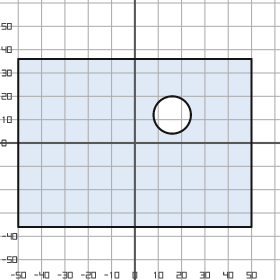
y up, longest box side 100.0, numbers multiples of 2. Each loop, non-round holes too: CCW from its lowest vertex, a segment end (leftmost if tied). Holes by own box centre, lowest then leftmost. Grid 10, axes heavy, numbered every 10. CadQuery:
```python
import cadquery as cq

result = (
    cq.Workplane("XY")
    .moveTo(-50.0, -36.0)
    .lineTo(50.0, -36.0)
    .lineTo(50.0, 36.0)
    .lineTo(-50.0, 36.0)
    .close()
    .moveTo(16.0, 12.0)
    .circle(8.0)
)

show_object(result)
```